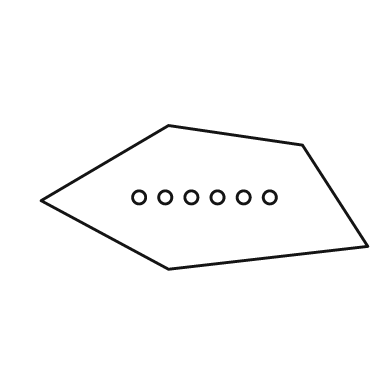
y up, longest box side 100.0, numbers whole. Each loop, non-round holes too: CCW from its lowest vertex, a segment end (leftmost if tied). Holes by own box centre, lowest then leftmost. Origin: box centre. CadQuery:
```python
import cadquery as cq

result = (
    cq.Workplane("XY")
    .moveTo(-11.0, -22.0)
    .lineTo(50.0, -15.0)
    .lineTo(30.0, 16.0)
    .lineTo(-11.0, 22.0)
    .lineTo(-50.0, -1.0)
    .close()
    .moveTo(-20.0, 0.0)
    .circle(2.0)
    .moveTo(-12.0, 0.0)
    .circle(2.0)
    .moveTo(-4.0, 0.0)
    .circle(2.0)
    .moveTo(4.0, 0.0)
    .circle(2.0)
    .moveTo(12.0, 0.0)
    .circle(2.0)
    .moveTo(20.0, 0.0)
    .circle(2.0)
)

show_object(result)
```